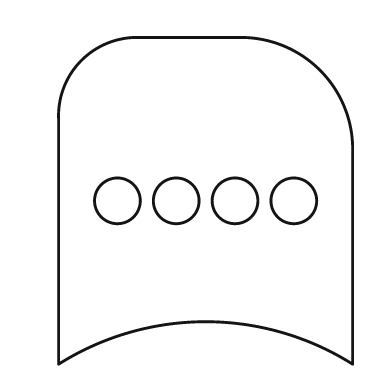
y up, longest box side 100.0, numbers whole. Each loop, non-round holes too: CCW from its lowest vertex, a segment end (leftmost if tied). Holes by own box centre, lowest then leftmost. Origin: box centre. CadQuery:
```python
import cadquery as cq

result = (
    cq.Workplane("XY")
    .moveTo(-45.0, -50.0)
    .threePointArc((0.0, -37.0), (45.0, -50.0))
    .lineTo(45.0, 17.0)
    .threePointArc((35.0, 40.0), (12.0, 50.0))
    .lineTo(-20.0, 50.0)
    .threePointArc((-38.0, 43.0), (-45.0, 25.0))
    .close()
    .moveTo(-27.0, 0.0)
    .circle(7.0)
    .moveTo(-9.0, 0.0)
    .circle(7.0)
    .moveTo(9.0, 0.0)
    .circle(7.0)
    .moveTo(27.0, 0.0)
    .circle(7.0)
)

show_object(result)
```